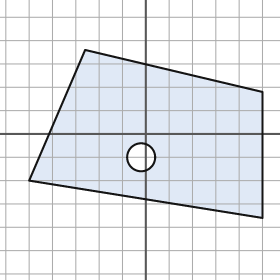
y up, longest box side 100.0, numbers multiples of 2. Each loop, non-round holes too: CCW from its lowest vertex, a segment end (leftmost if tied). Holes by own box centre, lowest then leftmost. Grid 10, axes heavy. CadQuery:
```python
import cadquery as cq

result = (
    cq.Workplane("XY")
    .moveTo(50.0, -36.0)
    .lineTo(50.0, 18.0)
    .lineTo(-26.0, 36.0)
    .lineTo(-50.0, -20.0)
    .close()
    .moveTo(-2.0, -10.0)
    .circle(6.0)
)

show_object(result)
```